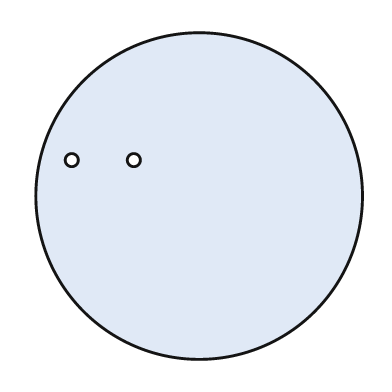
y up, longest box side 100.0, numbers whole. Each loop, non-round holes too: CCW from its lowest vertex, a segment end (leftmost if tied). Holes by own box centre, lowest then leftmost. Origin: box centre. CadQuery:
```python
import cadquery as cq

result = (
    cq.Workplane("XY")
    .moveTo(0.0, 0.0)
    .circle(50.0)
    .moveTo(-39.0, 11.0)
    .circle(2.0)
    .moveTo(-20.0, 11.0)
    .circle(2.0)
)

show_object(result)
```